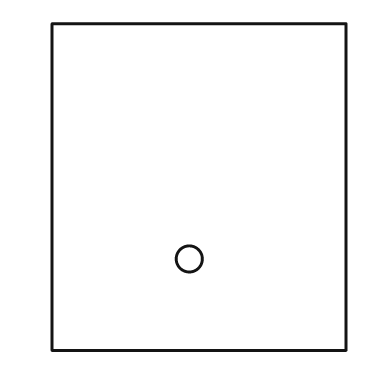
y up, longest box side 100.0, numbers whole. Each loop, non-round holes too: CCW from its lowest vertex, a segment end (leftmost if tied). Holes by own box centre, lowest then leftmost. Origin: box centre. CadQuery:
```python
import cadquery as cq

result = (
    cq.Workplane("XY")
    .moveTo(-45.0, -50.0)
    .lineTo(45.0, -50.0)
    .lineTo(45.0, 50.0)
    .lineTo(-45.0, 50.0)
    .close()
    .moveTo(-3.0, -22.0)
    .circle(4.0)
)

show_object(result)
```